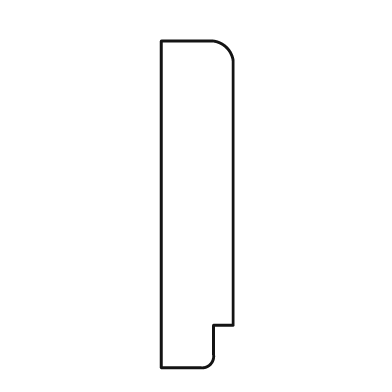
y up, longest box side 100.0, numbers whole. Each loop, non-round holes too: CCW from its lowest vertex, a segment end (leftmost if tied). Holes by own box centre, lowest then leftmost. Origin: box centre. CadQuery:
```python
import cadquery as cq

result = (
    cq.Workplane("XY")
    .moveTo(-11.0, -50.0)
    .lineTo(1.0, -50.0)
    .threePointArc((4.0, -49.0), (5.0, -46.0))
    .lineTo(5.0, -37.0)
    .lineTo(11.0, -37.0)
    .lineTo(11.0, 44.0)
    .threePointArc((9.0, 48.0), (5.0, 50.0))
    .lineTo(-11.0, 50.0)
    .close()
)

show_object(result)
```